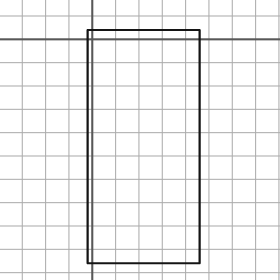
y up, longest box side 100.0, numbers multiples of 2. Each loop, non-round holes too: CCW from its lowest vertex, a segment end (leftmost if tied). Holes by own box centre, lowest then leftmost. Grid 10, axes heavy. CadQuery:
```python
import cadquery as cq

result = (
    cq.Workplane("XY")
    .moveTo(-2.0, -96.0)
    .lineTo(46.0, -96.0)
    .lineTo(46.0, 4.0)
    .lineTo(-2.0, 4.0)
    .close()
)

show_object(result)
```